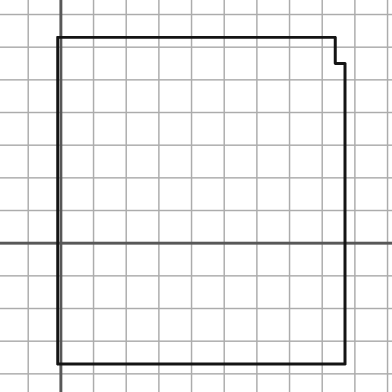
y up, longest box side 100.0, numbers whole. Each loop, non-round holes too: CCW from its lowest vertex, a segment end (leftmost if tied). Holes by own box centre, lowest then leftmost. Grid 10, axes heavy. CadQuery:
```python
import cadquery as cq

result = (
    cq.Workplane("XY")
    .moveTo(-1.0, -37.0)
    .lineTo(87.0, -37.0)
    .lineTo(87.0, 55.0)
    .lineTo(84.0, 55.0)
    .lineTo(84.0, 63.0)
    .lineTo(-1.0, 63.0)
    .close()
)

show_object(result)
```